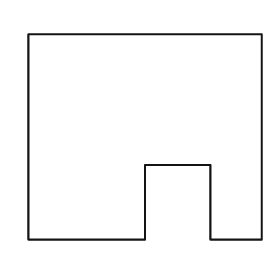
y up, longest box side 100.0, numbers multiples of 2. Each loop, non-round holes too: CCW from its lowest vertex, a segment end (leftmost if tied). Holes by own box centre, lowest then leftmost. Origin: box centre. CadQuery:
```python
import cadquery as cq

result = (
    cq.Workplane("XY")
    .moveTo(-50.0, -44.0)
    .lineTo(0.0, -44.0)
    .lineTo(0.0, -12.0)
    .lineTo(28.0, -12.0)
    .lineTo(28.0, -44.0)
    .lineTo(50.0, -44.0)
    .lineTo(50.0, 44.0)
    .lineTo(-50.0, 44.0)
    .close()
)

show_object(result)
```